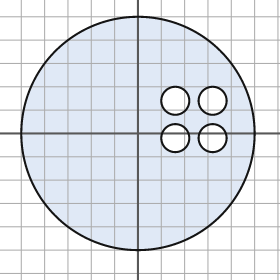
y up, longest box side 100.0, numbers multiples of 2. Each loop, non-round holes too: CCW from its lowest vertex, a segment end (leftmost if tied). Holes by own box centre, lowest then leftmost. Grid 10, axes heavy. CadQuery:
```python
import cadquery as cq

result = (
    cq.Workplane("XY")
    .moveTo(0.0, 0.0)
    .circle(50.0)
    .moveTo(16.0, -2.0)
    .circle(6.0)
    .moveTo(32.0, -2.0)
    .circle(6.0)
    .moveTo(16.0, 14.0)
    .circle(6.0)
    .moveTo(32.0, 14.0)
    .circle(6.0)
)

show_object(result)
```